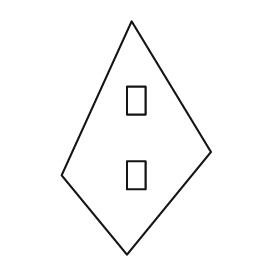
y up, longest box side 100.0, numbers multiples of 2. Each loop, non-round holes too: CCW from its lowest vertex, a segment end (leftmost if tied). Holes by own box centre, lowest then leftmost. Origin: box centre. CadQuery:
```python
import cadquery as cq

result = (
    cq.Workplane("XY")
    .moveTo(-4.0, -50.0)
    .lineTo(32.0, -6.0)
    .lineTo(-2.0, 50.0)
    .lineTo(-32.0, -16.0)
    .close()
    .moveTo(-4.0, -22.0)
    .lineTo(4.0, -22.0)
    .lineTo(4.0, -10.0)
    .lineTo(-4.0, -10.0)
    .close()
    .moveTo(-4.0, 10.0)
    .lineTo(4.0, 10.0)
    .lineTo(4.0, 22.0)
    .lineTo(-4.0, 22.0)
    .close()
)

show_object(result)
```